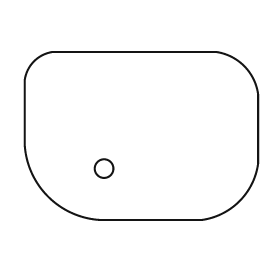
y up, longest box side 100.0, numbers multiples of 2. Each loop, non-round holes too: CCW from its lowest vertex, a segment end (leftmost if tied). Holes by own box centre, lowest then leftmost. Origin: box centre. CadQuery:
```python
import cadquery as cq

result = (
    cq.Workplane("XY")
    .moveTo(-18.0, -36.0)
    .lineTo(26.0, -36.0)
    .threePointArc((42.0, -28.0), (50.0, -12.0))
    .lineTo(50.0, 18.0)
    .threePointArc((44.0, 30.0), (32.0, 36.0))
    .lineTo(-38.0, 36.0)
    .threePointArc((-46.0, 32.0), (-50.0, 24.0))
    .lineTo(-50.0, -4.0)
    .threePointArc((-40.0, -26.0), (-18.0, -36.0))
    .close()
    .moveTo(-16.0, -14.0)
    .circle(4.0)
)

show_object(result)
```